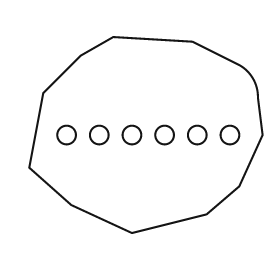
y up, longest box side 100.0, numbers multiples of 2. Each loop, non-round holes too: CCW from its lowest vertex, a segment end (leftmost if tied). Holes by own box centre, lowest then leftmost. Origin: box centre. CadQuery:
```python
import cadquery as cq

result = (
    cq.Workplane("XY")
    .moveTo(-6.0, -42.0)
    .lineTo(26.0, -34.0)
    .lineTo(40.0, -22.0)
    .lineTo(50.0, 0.0)
    .lineTo(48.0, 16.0)
    .threePointArc((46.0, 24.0), (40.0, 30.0))
    .lineTo(20.0, 40.0)
    .lineTo(-14.0, 42.0)
    .lineTo(-28.0, 34.0)
    .lineTo(-44.0, 18.0)
    .lineTo(-50.0, -14.0)
    .lineTo(-32.0, -30.0)
    .close()
    .moveTo(-34.0, 0.0)
    .circle(4.0)
    .moveTo(-20.0, 0.0)
    .circle(4.0)
    .moveTo(-6.0, 0.0)
    .circle(4.0)
    .moveTo(8.0, 0.0)
    .circle(4.0)
    .moveTo(22.0, 0.0)
    .circle(4.0)
    .moveTo(36.0, 0.0)
    .circle(4.0)
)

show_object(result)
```